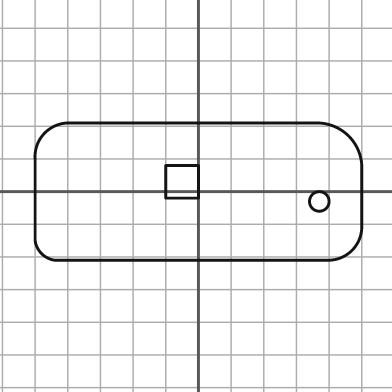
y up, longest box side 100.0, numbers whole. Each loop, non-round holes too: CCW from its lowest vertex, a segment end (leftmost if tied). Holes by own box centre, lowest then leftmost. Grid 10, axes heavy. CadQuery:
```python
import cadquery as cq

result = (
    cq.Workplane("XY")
    .moveTo(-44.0, -21.0)
    .lineTo(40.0, -21.0)
    .threePointArc((47.0, -18.0), (50.0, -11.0))
    .lineTo(50.0, 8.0)
    .threePointArc((46.0, 17.0), (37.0, 21.0))
    .lineTo(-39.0, 21.0)
    .threePointArc((-47.0, 18.0), (-50.0, 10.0))
    .lineTo(-50.0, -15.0)
    .threePointArc((-48.0, -19.0), (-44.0, -21.0))
    .close()
    .moveTo(37.0, -3.0)
    .circle(3.0)
    .moveTo(-10.0, -2.0)
    .lineTo(0.0, -2.0)
    .lineTo(0.0, 8.0)
    .lineTo(-10.0, 8.0)
    .close()
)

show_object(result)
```